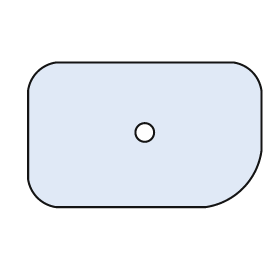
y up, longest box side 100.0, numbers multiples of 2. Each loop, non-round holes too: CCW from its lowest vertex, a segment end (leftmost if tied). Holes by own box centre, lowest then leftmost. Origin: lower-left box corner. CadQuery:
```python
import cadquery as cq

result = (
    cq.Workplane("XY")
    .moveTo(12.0, 0.0)
    .lineTo(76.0, 0.0)
    .threePointArc((92.0, 8.0), (100.0, 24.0))
    .lineTo(100.0, 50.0)
    .threePointArc((96.0, 58.0), (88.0, 62.0))
    .lineTo(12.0, 62.0)
    .threePointArc((4.0, 58.0), (0.0, 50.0))
    .lineTo(0.0, 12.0)
    .threePointArc((4.0, 4.0), (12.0, 0.0))
    .close()
    .moveTo(50.0, 32.0)
    .circle(4.0)
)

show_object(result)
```